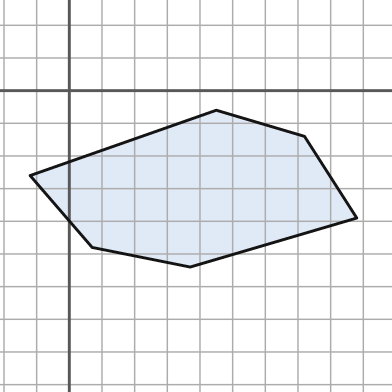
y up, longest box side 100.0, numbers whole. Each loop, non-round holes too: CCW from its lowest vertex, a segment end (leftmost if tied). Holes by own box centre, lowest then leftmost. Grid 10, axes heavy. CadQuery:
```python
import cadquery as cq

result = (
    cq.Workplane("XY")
    .moveTo(37.0, -54.0)
    .lineTo(88.0, -39.0)
    .lineTo(72.0, -14.0)
    .lineTo(45.0, -6.0)
    .lineTo(-12.0, -26.0)
    .lineTo(7.0, -48.0)
    .close()
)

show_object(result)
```